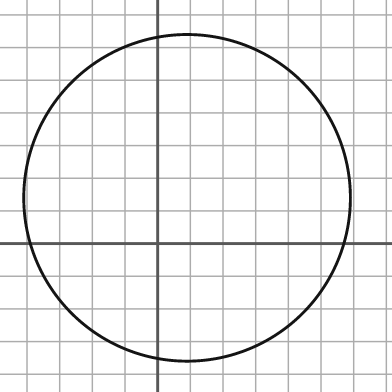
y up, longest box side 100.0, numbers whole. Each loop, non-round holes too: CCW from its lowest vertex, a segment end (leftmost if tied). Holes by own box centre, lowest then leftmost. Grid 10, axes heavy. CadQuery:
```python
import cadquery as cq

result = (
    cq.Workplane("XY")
    .moveTo(9.0, 14.0)
    .circle(50.0)
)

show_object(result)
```